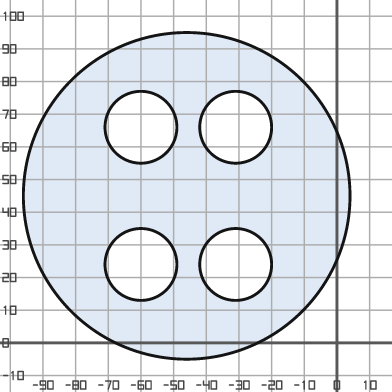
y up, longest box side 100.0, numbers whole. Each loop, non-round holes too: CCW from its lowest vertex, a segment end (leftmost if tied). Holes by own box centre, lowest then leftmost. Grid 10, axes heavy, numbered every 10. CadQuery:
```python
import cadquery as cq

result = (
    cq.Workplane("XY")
    .moveTo(-46.0, 45.0)
    .circle(50.0)
    .moveTo(-60.0, 24.0)
    .circle(11.0)
    .moveTo(-31.0, 24.0)
    .circle(11.0)
    .moveTo(-60.0, 66.0)
    .circle(11.0)
    .moveTo(-31.0, 66.0)
    .circle(11.0)
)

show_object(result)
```